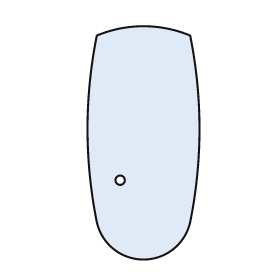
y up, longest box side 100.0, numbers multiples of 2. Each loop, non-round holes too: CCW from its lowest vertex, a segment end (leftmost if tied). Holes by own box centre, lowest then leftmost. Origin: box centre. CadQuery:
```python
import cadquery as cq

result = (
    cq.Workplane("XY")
    .moveTo(-20.0, -34.0)
    .threePointArc((0.0, -50.0), (20.0, -34.0))
    .threePointArc((24.0, 6.0), (20.0, 46.0))
    .threePointArc((0.0, 50.0), (-20.0, 46.0))
    .threePointArc((-24.0, 6.0), (-20.0, -34.0))
    .close()
    .moveTo(-10.0, -16.0)
    .circle(2.0)
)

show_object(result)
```